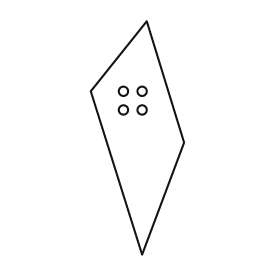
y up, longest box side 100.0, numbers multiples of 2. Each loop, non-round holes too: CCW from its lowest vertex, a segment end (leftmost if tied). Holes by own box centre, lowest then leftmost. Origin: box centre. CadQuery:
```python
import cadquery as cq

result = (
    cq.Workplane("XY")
    .moveTo(2.0, -50.0)
    .lineTo(20.0, -2.0)
    .lineTo(4.0, 50.0)
    .lineTo(-20.0, 20.0)
    .close()
    .moveTo(-6.0, 12.0)
    .circle(2.0)
    .moveTo(2.0, 12.0)
    .circle(2.0)
    .moveTo(-6.0, 20.0)
    .circle(2.0)
    .moveTo(2.0, 20.0)
    .circle(2.0)
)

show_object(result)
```